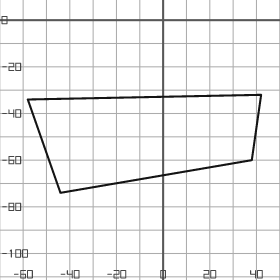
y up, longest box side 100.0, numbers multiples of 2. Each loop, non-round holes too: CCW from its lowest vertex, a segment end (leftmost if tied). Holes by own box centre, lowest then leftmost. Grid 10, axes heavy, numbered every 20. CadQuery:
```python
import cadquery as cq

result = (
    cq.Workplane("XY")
    .moveTo(-44.0, -74.0)
    .lineTo(38.0, -60.0)
    .lineTo(42.0, -32.0)
    .lineTo(-58.0, -34.0)
    .close()
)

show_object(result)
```